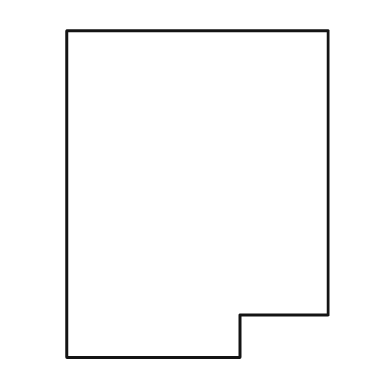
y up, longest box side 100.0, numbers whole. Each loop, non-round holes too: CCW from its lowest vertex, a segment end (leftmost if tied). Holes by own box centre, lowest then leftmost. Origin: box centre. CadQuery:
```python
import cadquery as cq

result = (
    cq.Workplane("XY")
    .moveTo(-40.0, -50.0)
    .lineTo(13.0, -50.0)
    .lineTo(13.0, -37.0)
    .lineTo(40.0, -37.0)
    .lineTo(40.0, 50.0)
    .lineTo(-40.0, 50.0)
    .close()
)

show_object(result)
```